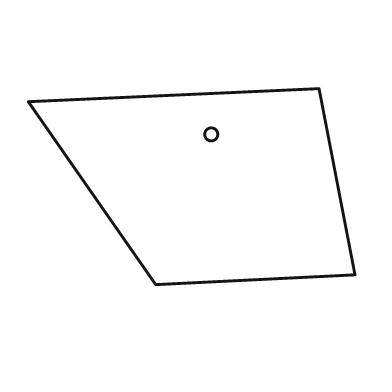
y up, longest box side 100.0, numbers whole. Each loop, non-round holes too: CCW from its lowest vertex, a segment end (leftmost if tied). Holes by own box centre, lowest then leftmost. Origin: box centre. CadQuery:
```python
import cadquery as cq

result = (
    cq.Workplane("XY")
    .moveTo(-11.0, -30.0)
    .lineTo(50.0, -27.0)
    .lineTo(39.0, 30.0)
    .lineTo(-50.0, 26.0)
    .close()
    .moveTo(6.0, 16.0)
    .circle(2.0)
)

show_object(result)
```